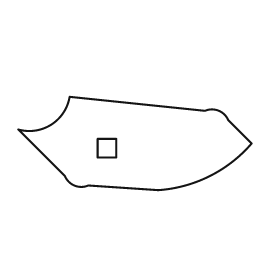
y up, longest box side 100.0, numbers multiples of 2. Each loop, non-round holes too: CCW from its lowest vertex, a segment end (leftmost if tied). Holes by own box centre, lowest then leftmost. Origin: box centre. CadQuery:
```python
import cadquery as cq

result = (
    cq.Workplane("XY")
    .moveTo(10.0, -20.0)
    .threePointArc((32.0, -14.0), (50.0, 0.0))
    .lineTo(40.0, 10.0)
    .threePointArc((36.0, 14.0), (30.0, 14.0))
    .lineTo(-28.0, 20.0)
    .threePointArc((-36.0, 8.0), (-50.0, 6.0))
    .lineTo(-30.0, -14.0)
    .threePointArc((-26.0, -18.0), (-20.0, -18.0))
    .close()
    .moveTo(-16.0, -6.0)
    .lineTo(-8.0, -6.0)
    .lineTo(-8.0, 2.0)
    .lineTo(-16.0, 2.0)
    .close()
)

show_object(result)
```